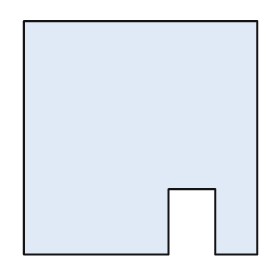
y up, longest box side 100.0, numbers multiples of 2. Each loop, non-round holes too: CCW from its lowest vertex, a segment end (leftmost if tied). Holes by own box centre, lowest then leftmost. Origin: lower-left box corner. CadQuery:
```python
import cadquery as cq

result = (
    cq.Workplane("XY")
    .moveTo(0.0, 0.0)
    .lineTo(62.0, 0.0)
    .lineTo(62.0, 28.0)
    .lineTo(82.0, 28.0)
    .lineTo(82.0, 0.0)
    .lineTo(100.0, 0.0)
    .lineTo(100.0, 100.0)
    .lineTo(0.0, 100.0)
    .close()
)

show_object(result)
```